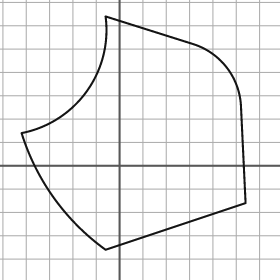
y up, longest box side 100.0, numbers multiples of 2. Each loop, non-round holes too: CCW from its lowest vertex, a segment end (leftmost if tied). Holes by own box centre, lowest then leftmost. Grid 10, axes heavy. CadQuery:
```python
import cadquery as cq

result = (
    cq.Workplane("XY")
    .moveTo(-6.0, -36.0)
    .lineTo(54.0, -16.0)
    .lineTo(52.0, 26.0)
    .threePointArc((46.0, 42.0), (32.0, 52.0))
    .lineTo(-6.0, 64.0)
    .threePointArc((-14.0, 32.0), (-42.0, 14.0))
    .threePointArc((-28.0, -14.0), (-6.0, -36.0))
    .close()
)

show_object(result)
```